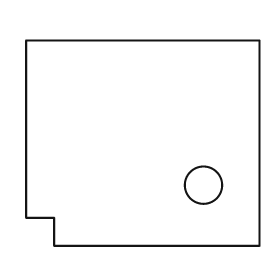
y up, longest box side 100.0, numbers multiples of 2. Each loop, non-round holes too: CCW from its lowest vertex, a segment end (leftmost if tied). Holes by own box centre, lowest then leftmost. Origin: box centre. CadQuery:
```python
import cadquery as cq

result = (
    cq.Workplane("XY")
    .moveTo(-38.0, -44.0)
    .lineTo(50.0, -44.0)
    .lineTo(50.0, 44.0)
    .lineTo(-50.0, 44.0)
    .lineTo(-50.0, -32.0)
    .lineTo(-38.0, -32.0)
    .close()
    .moveTo(26.0, -18.0)
    .circle(8.0)
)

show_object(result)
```